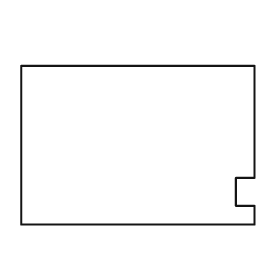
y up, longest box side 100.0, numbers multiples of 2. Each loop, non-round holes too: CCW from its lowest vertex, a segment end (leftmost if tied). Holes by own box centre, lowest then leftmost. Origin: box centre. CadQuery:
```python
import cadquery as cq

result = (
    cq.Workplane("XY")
    .moveTo(-50.0, -34.0)
    .lineTo(50.0, -34.0)
    .lineTo(50.0, -26.0)
    .lineTo(42.0, -26.0)
    .lineTo(42.0, -14.0)
    .lineTo(50.0, -14.0)
    .lineTo(50.0, 34.0)
    .lineTo(-50.0, 34.0)
    .close()
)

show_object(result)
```